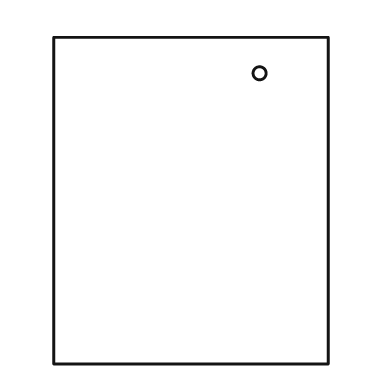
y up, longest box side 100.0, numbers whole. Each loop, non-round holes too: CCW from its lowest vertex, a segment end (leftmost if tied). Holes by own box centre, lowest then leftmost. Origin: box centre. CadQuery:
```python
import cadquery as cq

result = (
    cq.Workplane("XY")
    .moveTo(-42.0, -50.0)
    .lineTo(42.0, -50.0)
    .lineTo(42.0, 50.0)
    .lineTo(-42.0, 50.0)
    .close()
    .moveTo(21.0, 39.0)
    .circle(2.0)
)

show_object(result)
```